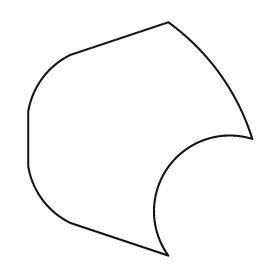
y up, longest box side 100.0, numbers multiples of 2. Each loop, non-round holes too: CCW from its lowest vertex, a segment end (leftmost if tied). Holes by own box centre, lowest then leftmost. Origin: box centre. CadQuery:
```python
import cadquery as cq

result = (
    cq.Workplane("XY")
    .moveTo(12.0, -50.0)
    .threePointArc((12.0, -12.0), (48.0, 0.0))
    .threePointArc((34.0, 28.0), (12.0, 50.0))
    .lineTo(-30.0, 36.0)
    .threePointArc((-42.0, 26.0), (-48.0, 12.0))
    .lineTo(-48.0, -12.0)
    .threePointArc((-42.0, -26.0), (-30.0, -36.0))
    .close()
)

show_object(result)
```